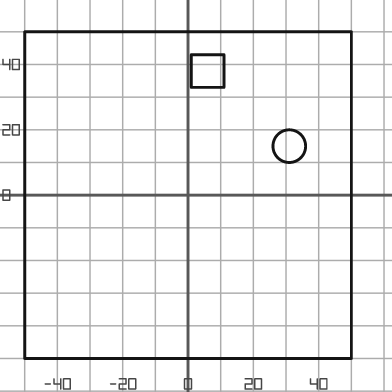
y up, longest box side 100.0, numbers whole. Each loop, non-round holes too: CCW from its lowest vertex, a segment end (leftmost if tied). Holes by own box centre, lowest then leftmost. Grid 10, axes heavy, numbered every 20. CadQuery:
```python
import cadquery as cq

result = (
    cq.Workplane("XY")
    .moveTo(-50.0, -50.0)
    .lineTo(50.0, -50.0)
    .lineTo(50.0, 50.0)
    .lineTo(-50.0, 50.0)
    .close()
    .moveTo(31.0, 15.0)
    .circle(5.0)
    .moveTo(1.0, 33.0)
    .lineTo(11.0, 33.0)
    .lineTo(11.0, 43.0)
    .lineTo(1.0, 43.0)
    .close()
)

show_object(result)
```